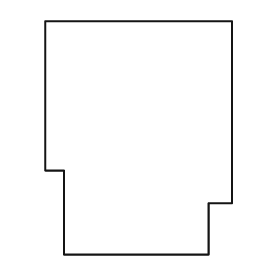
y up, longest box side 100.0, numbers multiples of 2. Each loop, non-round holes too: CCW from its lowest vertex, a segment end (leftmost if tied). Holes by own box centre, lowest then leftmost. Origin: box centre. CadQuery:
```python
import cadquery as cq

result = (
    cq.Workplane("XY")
    .moveTo(-32.0, -50.0)
    .lineTo(30.0, -50.0)
    .lineTo(30.0, -28.0)
    .lineTo(40.0, -28.0)
    .lineTo(40.0, 50.0)
    .lineTo(-40.0, 50.0)
    .lineTo(-40.0, -14.0)
    .lineTo(-32.0, -14.0)
    .close()
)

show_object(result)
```